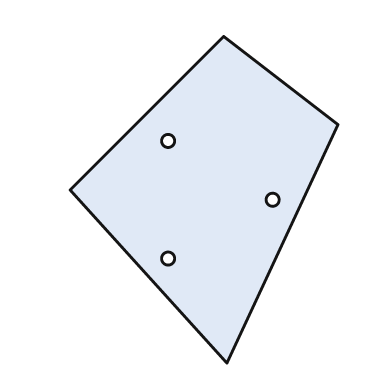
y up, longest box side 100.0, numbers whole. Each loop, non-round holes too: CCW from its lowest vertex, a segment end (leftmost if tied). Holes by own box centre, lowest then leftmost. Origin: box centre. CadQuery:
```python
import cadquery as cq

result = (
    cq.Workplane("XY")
    .moveTo(7.0, -50.0)
    .lineTo(41.0, 23.0)
    .lineTo(6.0, 50.0)
    .lineTo(-41.0, 3.0)
    .close()
    .moveTo(-11.0, -18.0)
    .circle(2.0)
    .moveTo(21.0, 0.0)
    .circle(2.0)
    .moveTo(-11.0, 18.0)
    .circle(2.0)
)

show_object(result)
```